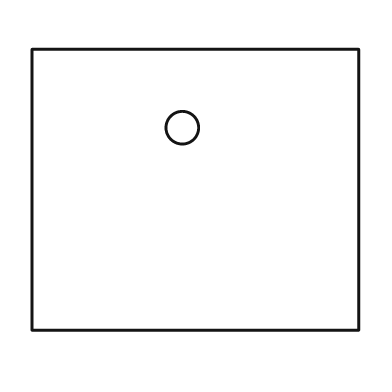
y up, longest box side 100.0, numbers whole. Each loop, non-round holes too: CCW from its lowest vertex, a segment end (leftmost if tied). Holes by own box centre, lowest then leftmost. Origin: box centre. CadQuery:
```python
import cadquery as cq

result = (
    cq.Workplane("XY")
    .moveTo(-50.0, -43.0)
    .lineTo(50.0, -43.0)
    .lineTo(50.0, 43.0)
    .lineTo(-50.0, 43.0)
    .close()
    .moveTo(-4.0, 19.0)
    .circle(5.0)
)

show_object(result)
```